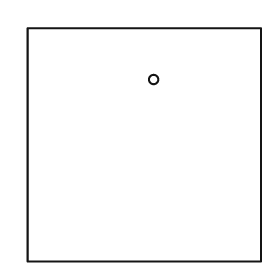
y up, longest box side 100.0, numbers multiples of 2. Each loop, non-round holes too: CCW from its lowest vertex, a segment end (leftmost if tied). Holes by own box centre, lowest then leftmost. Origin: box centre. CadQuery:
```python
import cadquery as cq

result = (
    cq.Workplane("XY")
    .moveTo(-50.0, -50.0)
    .lineTo(50.0, -50.0)
    .lineTo(50.0, 50.0)
    .lineTo(-50.0, 50.0)
    .close()
    .moveTo(4.0, 28.0)
    .circle(2.0)
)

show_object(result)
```